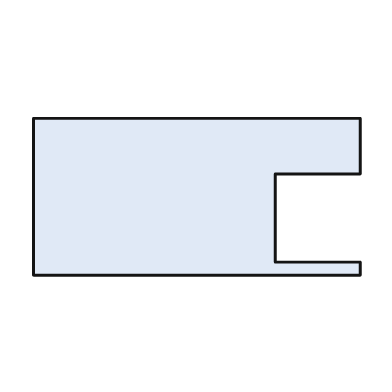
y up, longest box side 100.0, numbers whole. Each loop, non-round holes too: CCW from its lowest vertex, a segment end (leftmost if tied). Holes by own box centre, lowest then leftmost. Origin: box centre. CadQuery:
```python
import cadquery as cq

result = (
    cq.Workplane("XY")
    .moveTo(-50.0, -24.0)
    .lineTo(50.0, -24.0)
    .lineTo(50.0, -20.0)
    .lineTo(24.0, -20.0)
    .lineTo(24.0, 7.0)
    .lineTo(50.0, 7.0)
    .lineTo(50.0, 24.0)
    .lineTo(-50.0, 24.0)
    .close()
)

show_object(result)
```